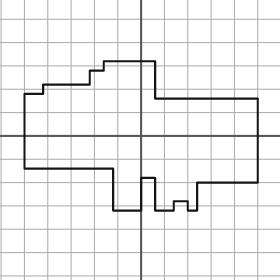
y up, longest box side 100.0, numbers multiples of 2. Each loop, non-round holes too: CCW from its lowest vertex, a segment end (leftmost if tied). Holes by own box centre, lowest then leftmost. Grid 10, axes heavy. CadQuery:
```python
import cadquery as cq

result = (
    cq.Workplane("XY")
    .moveTo(-12.0, -32.0)
    .lineTo(0.0, -32.0)
    .lineTo(0.0, -18.0)
    .lineTo(6.0, -18.0)
    .lineTo(6.0, -32.0)
    .lineTo(14.0, -32.0)
    .lineTo(14.0, -28.0)
    .lineTo(20.0, -28.0)
    .lineTo(20.0, -32.0)
    .lineTo(24.0, -32.0)
    .lineTo(24.0, -20.0)
    .lineTo(50.0, -20.0)
    .lineTo(50.0, 16.0)
    .lineTo(6.0, 16.0)
    .lineTo(6.0, 32.0)
    .lineTo(-16.0, 32.0)
    .lineTo(-16.0, 28.0)
    .lineTo(-22.0, 28.0)
    .lineTo(-22.0, 22.0)
    .lineTo(-42.0, 22.0)
    .lineTo(-42.0, 18.0)
    .lineTo(-50.0, 18.0)
    .lineTo(-50.0, -14.0)
    .lineTo(-12.0, -14.0)
    .close()
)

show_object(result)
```